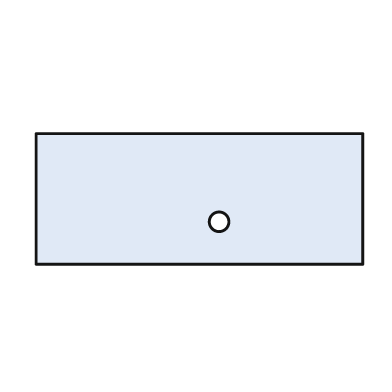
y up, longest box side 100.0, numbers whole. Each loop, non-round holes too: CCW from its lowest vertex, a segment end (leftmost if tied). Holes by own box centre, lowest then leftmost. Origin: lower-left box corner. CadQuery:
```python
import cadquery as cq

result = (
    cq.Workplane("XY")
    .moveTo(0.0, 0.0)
    .lineTo(100.0, 0.0)
    .lineTo(100.0, 40.0)
    .lineTo(0.0, 40.0)
    .close()
    .moveTo(56.0, 13.0)
    .circle(3.0)
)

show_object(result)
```